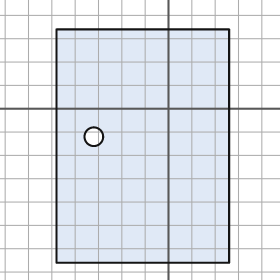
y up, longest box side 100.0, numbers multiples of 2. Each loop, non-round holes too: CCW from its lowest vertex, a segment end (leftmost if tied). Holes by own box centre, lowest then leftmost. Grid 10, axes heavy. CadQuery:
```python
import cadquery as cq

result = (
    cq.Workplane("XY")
    .moveTo(-48.0, -66.0)
    .lineTo(26.0, -66.0)
    .lineTo(26.0, 34.0)
    .lineTo(-48.0, 34.0)
    .close()
    .moveTo(-32.0, -12.0)
    .circle(4.0)
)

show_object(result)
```